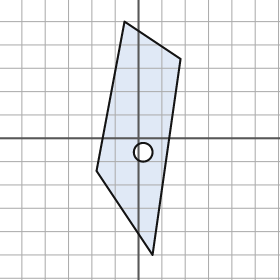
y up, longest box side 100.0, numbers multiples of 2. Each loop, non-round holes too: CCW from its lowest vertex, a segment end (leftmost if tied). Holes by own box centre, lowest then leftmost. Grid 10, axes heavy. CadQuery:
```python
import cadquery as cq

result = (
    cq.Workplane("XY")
    .moveTo(6.0, -50.0)
    .lineTo(18.0, 34.0)
    .lineTo(-6.0, 50.0)
    .lineTo(-18.0, -14.0)
    .close()
    .moveTo(2.0, -6.0)
    .circle(4.0)
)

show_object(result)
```